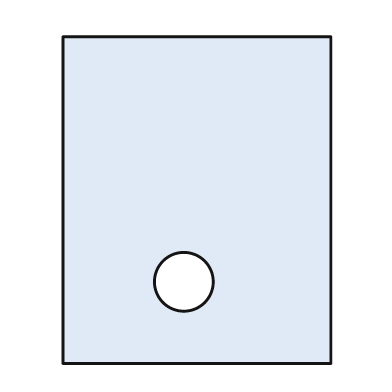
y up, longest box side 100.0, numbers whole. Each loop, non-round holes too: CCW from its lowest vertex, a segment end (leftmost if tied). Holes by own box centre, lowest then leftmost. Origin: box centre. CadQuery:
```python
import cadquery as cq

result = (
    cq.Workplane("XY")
    .moveTo(-41.0, -50.0)
    .lineTo(41.0, -50.0)
    .lineTo(41.0, 50.0)
    .lineTo(-41.0, 50.0)
    .close()
    .moveTo(-4.0, -25.0)
    .circle(9.0)
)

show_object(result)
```